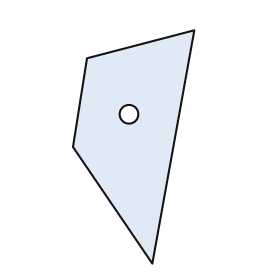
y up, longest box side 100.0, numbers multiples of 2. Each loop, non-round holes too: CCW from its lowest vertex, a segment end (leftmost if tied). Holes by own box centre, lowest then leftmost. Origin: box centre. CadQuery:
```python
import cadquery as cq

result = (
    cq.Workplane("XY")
    .moveTo(8.0, -50.0)
    .lineTo(26.0, 50.0)
    .lineTo(-20.0, 38.0)
    .lineTo(-26.0, 0.0)
    .close()
    .moveTo(-2.0, 14.0)
    .circle(4.0)
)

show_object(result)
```